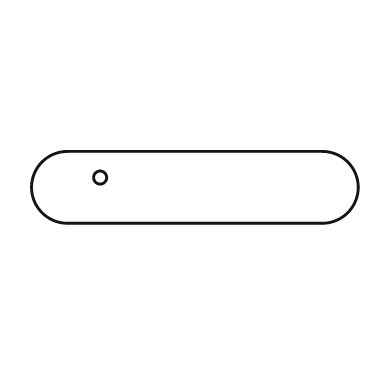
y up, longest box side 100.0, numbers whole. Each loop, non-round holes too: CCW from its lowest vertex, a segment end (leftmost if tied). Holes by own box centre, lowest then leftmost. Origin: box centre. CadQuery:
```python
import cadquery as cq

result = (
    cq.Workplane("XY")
    .moveTo(-39.0, -11.0)
    .lineTo(39.0, -11.0)
    .threePointArc((50.0, 0.0), (39.0, 11.0))
    .lineTo(-39.0, 11.0)
    .threePointArc((-50.0, 0.0), (-39.0, -11.0))
    .close()
    .moveTo(-29.0, 3.0)
    .circle(2.0)
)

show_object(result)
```